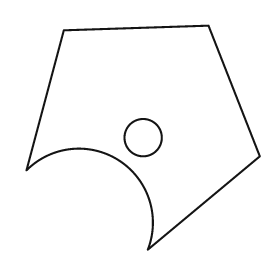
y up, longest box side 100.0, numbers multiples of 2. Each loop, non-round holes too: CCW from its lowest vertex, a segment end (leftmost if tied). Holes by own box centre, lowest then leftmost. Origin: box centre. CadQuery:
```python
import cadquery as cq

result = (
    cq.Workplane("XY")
    .moveTo(2.0, -48.0)
    .lineTo(50.0, -8.0)
    .lineTo(28.0, 48.0)
    .lineTo(-34.0, 46.0)
    .lineTo(-50.0, -14.0)
    .threePointArc((-10.0, -10.0), (2.0, -48.0))
    .close()
    .moveTo(0.0, 0.0)
    .circle(8.0)
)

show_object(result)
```